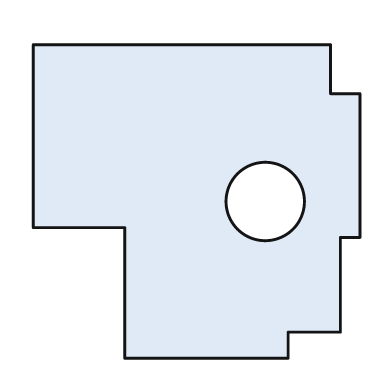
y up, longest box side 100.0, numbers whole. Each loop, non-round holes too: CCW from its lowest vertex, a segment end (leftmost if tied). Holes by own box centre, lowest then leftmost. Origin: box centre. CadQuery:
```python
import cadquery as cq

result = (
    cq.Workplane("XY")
    .moveTo(-22.0, -48.0)
    .lineTo(28.0, -48.0)
    .lineTo(28.0, -40.0)
    .lineTo(44.0, -40.0)
    .lineTo(44.0, -11.0)
    .lineTo(50.0, -11.0)
    .lineTo(50.0, 33.0)
    .lineTo(41.0, 33.0)
    .lineTo(41.0, 48.0)
    .lineTo(-50.0, 48.0)
    .lineTo(-50.0, -8.0)
    .lineTo(-22.0, -8.0)
    .close()
    .moveTo(21.0, 0.0)
    .circle(12.0)
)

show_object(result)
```